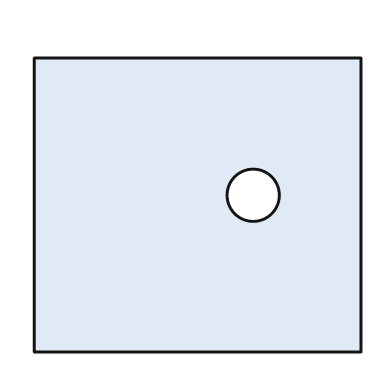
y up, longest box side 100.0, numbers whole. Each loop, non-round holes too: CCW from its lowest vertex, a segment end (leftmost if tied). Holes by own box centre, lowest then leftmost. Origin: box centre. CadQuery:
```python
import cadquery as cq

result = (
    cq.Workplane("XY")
    .moveTo(-50.0, -45.0)
    .lineTo(50.0, -45.0)
    .lineTo(50.0, 45.0)
    .lineTo(-50.0, 45.0)
    .close()
    .moveTo(17.0, 3.0)
    .circle(8.0)
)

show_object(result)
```